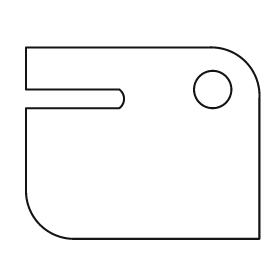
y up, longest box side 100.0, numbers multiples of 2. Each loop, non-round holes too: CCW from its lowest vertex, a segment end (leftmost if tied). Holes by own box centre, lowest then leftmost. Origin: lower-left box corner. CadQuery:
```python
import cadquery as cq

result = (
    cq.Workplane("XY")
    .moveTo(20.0, 0.0)
    .lineTo(100.0, 0.0)
    .lineTo(100.0, 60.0)
    .threePointArc((94.0, 76.0), (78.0, 82.0))
    .lineTo(0.0, 82.0)
    .lineTo(0.0, 64.0)
    .lineTo(40.0, 64.0)
    .threePointArc((42.0, 60.0), (40.0, 56.0))
    .lineTo(0.0, 56.0)
    .lineTo(0.0, 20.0)
    .threePointArc((6.0, 6.0), (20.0, 0.0))
    .close()
    .moveTo(80.0, 64.0)
    .circle(8.0)
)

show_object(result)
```